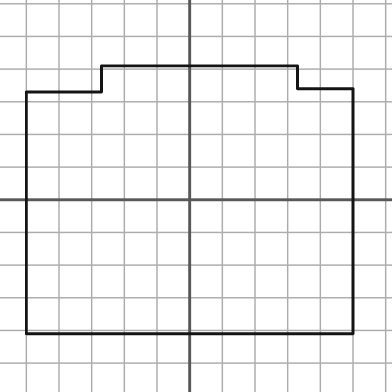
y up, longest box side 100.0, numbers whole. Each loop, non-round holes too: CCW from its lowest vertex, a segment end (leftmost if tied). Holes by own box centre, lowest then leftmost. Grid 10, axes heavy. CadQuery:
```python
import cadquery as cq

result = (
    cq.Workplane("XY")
    .moveTo(-50.0, -41.0)
    .lineTo(50.0, -41.0)
    .lineTo(50.0, 34.0)
    .lineTo(33.0, 34.0)
    .lineTo(33.0, 41.0)
    .lineTo(-27.0, 41.0)
    .lineTo(-27.0, 33.0)
    .lineTo(-50.0, 33.0)
    .close()
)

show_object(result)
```